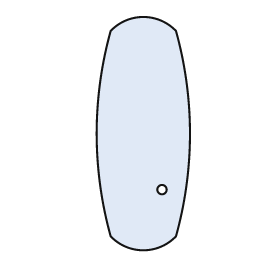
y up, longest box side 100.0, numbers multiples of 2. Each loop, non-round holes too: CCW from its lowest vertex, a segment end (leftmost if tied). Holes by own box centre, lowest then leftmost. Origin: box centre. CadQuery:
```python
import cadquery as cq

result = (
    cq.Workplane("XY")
    .moveTo(-14.0, -44.0)
    .threePointArc((0.0, -50.0), (14.0, -44.0))
    .threePointArc((20.0, 0.0), (14.0, 44.0))
    .threePointArc((0.0, 50.0), (-14.0, 44.0))
    .threePointArc((-20.0, 0.0), (-14.0, -44.0))
    .close()
    .moveTo(8.0, -24.0)
    .circle(2.0)
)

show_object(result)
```